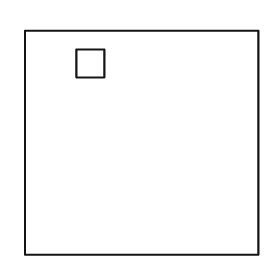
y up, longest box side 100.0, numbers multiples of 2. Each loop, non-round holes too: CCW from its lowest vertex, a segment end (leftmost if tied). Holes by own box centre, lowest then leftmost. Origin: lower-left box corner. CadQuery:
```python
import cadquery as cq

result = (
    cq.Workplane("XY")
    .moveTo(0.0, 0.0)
    .lineTo(100.0, 0.0)
    .lineTo(100.0, 96.0)
    .lineTo(0.0, 96.0)
    .close()
    .moveTo(22.0, 76.0)
    .lineTo(34.0, 76.0)
    .lineTo(34.0, 88.0)
    .lineTo(22.0, 88.0)
    .close()
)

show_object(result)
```